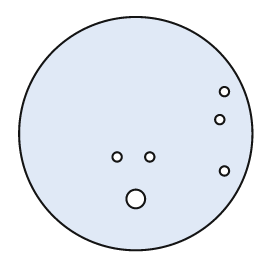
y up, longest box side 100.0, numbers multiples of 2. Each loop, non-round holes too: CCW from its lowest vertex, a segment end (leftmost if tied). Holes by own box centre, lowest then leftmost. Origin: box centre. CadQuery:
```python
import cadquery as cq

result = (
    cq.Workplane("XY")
    .moveTo(0.0, 0.0)
    .circle(50.0)
    .moveTo(0.0, -28.0)
    .circle(4.0)
    .moveTo(38.0, -16.0)
    .circle(2.0)
    .moveTo(-8.0, -10.0)
    .circle(2.0)
    .moveTo(6.0, -10.0)
    .circle(2.0)
    .moveTo(36.0, 6.0)
    .circle(2.0)
    .moveTo(38.0, 18.0)
    .circle(2.0)
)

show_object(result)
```